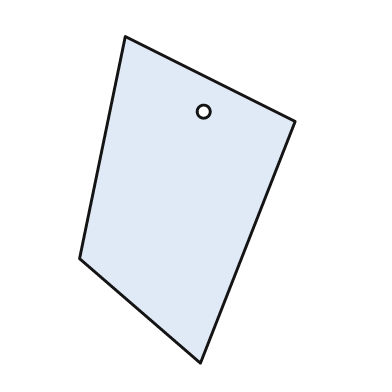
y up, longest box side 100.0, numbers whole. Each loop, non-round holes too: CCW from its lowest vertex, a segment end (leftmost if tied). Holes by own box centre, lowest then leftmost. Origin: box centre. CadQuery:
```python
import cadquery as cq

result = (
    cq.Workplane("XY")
    .moveTo(4.0, -50.0)
    .lineTo(33.0, 24.0)
    .lineTo(-19.0, 50.0)
    .lineTo(-33.0, -18.0)
    .close()
    .moveTo(5.0, 27.0)
    .circle(2.0)
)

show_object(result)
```